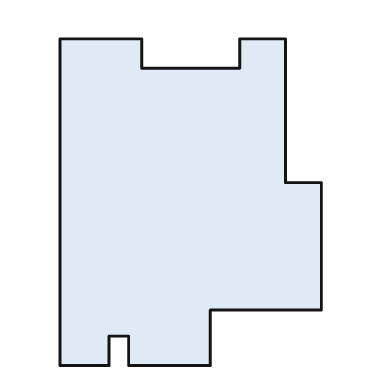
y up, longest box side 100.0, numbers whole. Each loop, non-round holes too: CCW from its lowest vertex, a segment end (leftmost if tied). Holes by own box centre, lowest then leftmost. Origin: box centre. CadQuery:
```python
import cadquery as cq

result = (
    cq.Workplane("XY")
    .moveTo(-40.0, -50.0)
    .lineTo(-25.0, -50.0)
    .lineTo(-25.0, -41.0)
    .lineTo(-19.0, -41.0)
    .lineTo(-19.0, -50.0)
    .lineTo(6.0, -50.0)
    .lineTo(6.0, -33.0)
    .lineTo(40.0, -33.0)
    .lineTo(40.0, 6.0)
    .lineTo(29.0, 6.0)
    .lineTo(29.0, 50.0)
    .lineTo(15.0, 50.0)
    .lineTo(15.0, 41.0)
    .lineTo(-15.0, 41.0)
    .lineTo(-15.0, 50.0)
    .lineTo(-40.0, 50.0)
    .close()
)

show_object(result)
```